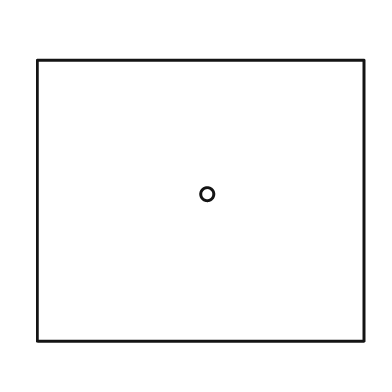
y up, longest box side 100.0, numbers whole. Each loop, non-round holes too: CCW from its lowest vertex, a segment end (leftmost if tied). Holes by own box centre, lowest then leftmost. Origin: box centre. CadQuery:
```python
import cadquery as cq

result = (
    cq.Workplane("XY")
    .moveTo(-50.0, -43.0)
    .lineTo(50.0, -43.0)
    .lineTo(50.0, 43.0)
    .lineTo(-50.0, 43.0)
    .close()
    .moveTo(2.0, 2.0)
    .circle(2.0)
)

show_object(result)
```